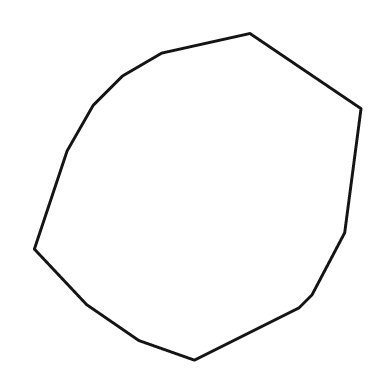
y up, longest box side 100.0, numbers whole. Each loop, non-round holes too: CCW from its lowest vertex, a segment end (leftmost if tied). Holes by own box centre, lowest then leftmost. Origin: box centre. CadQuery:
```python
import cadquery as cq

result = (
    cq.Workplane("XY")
    .moveTo(-1.0, -50.0)
    .lineTo(31.0, -34.0)
    .lineTo(35.0, -30.0)
    .lineTo(45.0, -11.0)
    .lineTo(50.0, 27.0)
    .lineTo(16.0, 50.0)
    .lineTo(-11.0, 44.0)
    .lineTo(-23.0, 37.0)
    .lineTo(-32.0, 28.0)
    .lineTo(-40.0, 14.0)
    .lineTo(-50.0, -16.0)
    .lineTo(-34.0, -33.0)
    .lineTo(-18.0, -44.0)
    .close()
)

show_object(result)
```